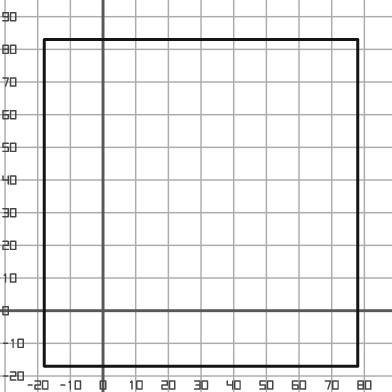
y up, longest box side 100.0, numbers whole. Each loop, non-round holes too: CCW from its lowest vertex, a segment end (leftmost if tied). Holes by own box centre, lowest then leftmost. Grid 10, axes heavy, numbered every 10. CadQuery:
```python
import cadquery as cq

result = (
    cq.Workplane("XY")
    .moveTo(-18.0, -17.0)
    .lineTo(78.0, -17.0)
    .lineTo(78.0, 83.0)
    .lineTo(-18.0, 83.0)
    .close()
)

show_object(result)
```